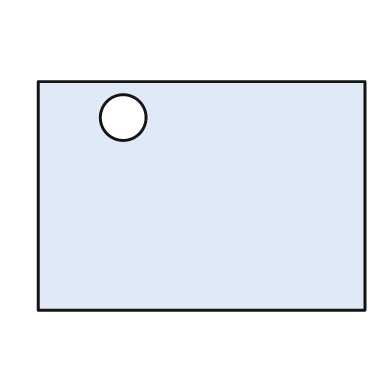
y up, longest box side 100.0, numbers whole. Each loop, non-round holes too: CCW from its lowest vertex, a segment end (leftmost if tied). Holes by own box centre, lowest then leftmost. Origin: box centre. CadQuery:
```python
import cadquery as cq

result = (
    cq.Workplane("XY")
    .moveTo(-50.0, -35.0)
    .lineTo(50.0, -35.0)
    .lineTo(50.0, 35.0)
    .lineTo(-50.0, 35.0)
    .close()
    .moveTo(-24.0, 24.0)
    .circle(7.0)
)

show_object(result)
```